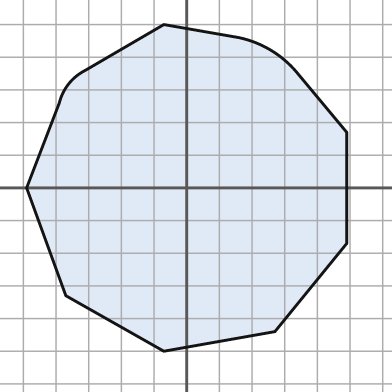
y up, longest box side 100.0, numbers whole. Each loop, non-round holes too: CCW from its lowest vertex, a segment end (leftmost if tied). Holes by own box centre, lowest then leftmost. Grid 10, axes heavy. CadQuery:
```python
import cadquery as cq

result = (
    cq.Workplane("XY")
    .moveTo(-7.0, -50.0)
    .lineTo(27.0, -44.0)
    .lineTo(49.0, -17.0)
    .lineTo(49.0, 17.0)
    .lineTo(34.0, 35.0)
    .threePointArc((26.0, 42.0), (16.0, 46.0))
    .lineTo(-7.0, 50.0)
    .lineTo(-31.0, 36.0)
    .threePointArc((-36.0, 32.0), (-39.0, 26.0))
    .lineTo(-49.0, 0.0)
    .lineTo(-37.0, -33.0)
    .close()
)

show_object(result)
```